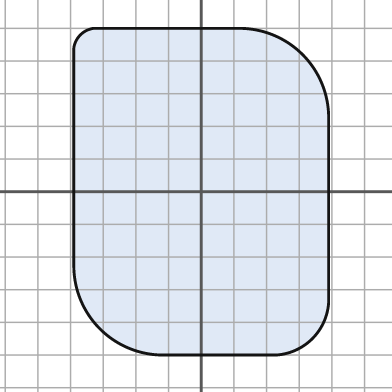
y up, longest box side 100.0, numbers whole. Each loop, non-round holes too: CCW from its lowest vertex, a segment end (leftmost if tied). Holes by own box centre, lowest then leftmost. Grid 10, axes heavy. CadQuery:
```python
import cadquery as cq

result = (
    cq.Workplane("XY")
    .moveTo(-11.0, -50.0)
    .lineTo(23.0, -50.0)
    .threePointArc((34.0, -45.0), (39.0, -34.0))
    .lineTo(39.0, 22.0)
    .threePointArc((31.0, 42.0), (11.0, 50.0))
    .lineTo(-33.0, 50.0)
    .threePointArc((-37.0, 48.0), (-39.0, 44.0))
    .lineTo(-39.0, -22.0)
    .threePointArc((-31.0, -42.0), (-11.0, -50.0))
    .close()
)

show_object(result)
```